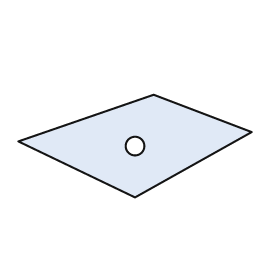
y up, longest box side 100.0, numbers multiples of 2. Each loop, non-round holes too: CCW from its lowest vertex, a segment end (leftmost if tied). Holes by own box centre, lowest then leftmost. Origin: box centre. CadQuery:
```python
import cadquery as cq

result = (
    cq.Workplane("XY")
    .moveTo(0.0, -22.0)
    .lineTo(50.0, 6.0)
    .lineTo(8.0, 22.0)
    .lineTo(-50.0, 2.0)
    .close()
    .moveTo(0.0, 0.0)
    .circle(4.0)
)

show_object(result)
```